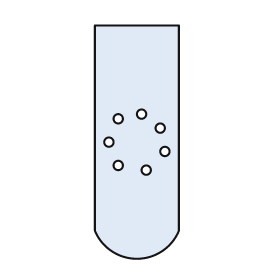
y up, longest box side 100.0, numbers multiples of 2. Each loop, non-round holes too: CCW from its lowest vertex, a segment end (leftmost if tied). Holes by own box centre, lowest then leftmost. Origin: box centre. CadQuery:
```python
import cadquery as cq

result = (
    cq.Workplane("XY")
    .moveTo(-18.0, -38.0)
    .threePointArc((0.0, -50.0), (18.0, -38.0))
    .lineTo(18.0, 50.0)
    .lineTo(-18.0, 50.0)
    .close()
    .moveTo(4.0, -12.0)
    .circle(2.0)
    .moveTo(-8.0, -10.0)
    .circle(2.0)
    .moveTo(12.0, -4.0)
    .circle(2.0)
    .moveTo(-12.0, 0.0)
    .circle(2.0)
    .moveTo(10.0, 6.0)
    .circle(2.0)
    .moveTo(-8.0, 10.0)
    .circle(2.0)
    .moveTo(2.0, 12.0)
    .circle(2.0)
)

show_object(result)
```